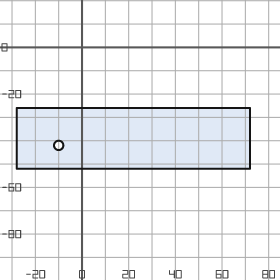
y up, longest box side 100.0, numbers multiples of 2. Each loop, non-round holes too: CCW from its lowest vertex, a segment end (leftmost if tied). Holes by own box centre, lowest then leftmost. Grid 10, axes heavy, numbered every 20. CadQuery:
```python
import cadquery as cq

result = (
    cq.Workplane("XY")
    .moveTo(-28.0, -52.0)
    .lineTo(72.0, -52.0)
    .lineTo(72.0, -26.0)
    .lineTo(-28.0, -26.0)
    .close()
    .moveTo(-10.0, -42.0)
    .circle(2.0)
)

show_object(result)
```